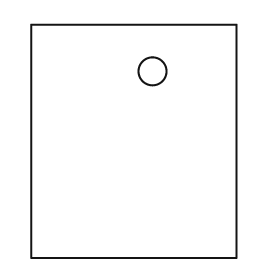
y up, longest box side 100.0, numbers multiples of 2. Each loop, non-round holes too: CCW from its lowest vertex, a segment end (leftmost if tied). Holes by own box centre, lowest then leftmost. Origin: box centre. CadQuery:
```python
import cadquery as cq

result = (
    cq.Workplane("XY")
    .moveTo(-44.0, -50.0)
    .lineTo(44.0, -50.0)
    .lineTo(44.0, 50.0)
    .lineTo(-44.0, 50.0)
    .close()
    .moveTo(8.0, 30.0)
    .circle(6.0)
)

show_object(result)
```